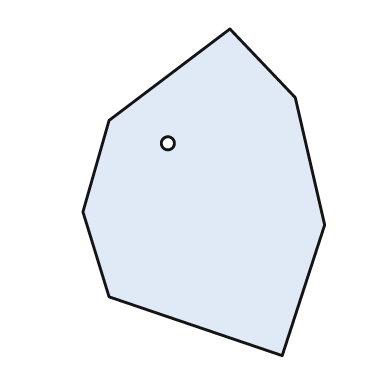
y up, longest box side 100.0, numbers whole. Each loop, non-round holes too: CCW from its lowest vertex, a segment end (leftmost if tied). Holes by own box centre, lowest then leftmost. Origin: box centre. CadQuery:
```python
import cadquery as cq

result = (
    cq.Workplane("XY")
    .moveTo(24.0, -50.0)
    .lineTo(37.0, -10.0)
    .lineTo(28.0, 29.0)
    .lineTo(8.0, 50.0)
    .lineTo(-29.0, 22.0)
    .lineTo(-37.0, -6.0)
    .lineTo(-29.0, -32.0)
    .close()
    .moveTo(-11.0, 15.0)
    .circle(2.0)
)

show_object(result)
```